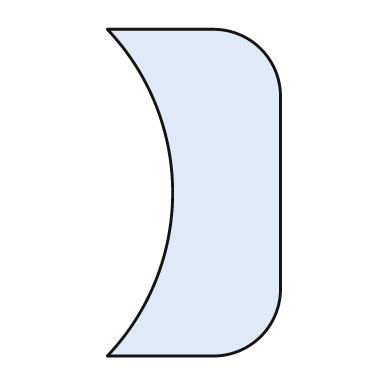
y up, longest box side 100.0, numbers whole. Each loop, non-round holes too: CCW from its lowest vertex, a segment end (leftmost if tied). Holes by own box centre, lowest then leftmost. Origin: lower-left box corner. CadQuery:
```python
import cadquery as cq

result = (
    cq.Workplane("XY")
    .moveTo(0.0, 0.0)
    .lineTo(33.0, 0.0)
    .threePointArc((47.0, 6.0), (53.0, 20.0))
    .lineTo(53.0, 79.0)
    .threePointArc((47.0, 94.0), (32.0, 100.0))
    .lineTo(0.0, 100.0)
    .threePointArc((20.0, 50.0), (0.0, 0.0))
    .close()
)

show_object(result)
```